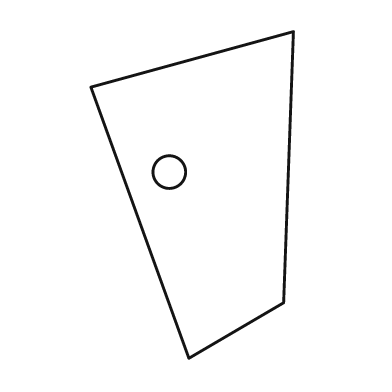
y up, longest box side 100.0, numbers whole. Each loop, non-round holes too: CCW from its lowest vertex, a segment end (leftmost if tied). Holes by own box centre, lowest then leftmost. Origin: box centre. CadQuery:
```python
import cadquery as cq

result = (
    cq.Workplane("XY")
    .moveTo(-1.0, -50.0)
    .lineTo(28.0, -33.0)
    .lineTo(31.0, 50.0)
    .lineTo(-31.0, 33.0)
    .close()
    .moveTo(-7.0, 7.0)
    .circle(5.0)
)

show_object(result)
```